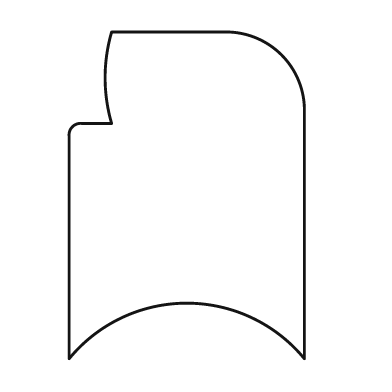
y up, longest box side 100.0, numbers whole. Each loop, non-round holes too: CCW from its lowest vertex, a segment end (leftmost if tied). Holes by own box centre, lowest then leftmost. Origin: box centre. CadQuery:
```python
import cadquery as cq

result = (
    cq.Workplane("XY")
    .moveTo(-36.0, -50.0)
    .threePointArc((0.0, -33.0), (36.0, -50.0))
    .lineTo(36.0, 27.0)
    .threePointArc((29.0, 43.0), (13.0, 50.0))
    .lineTo(-23.0, 50.0)
    .threePointArc((-25.0, 36.0), (-23.0, 22.0))
    .lineTo(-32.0, 22.0)
    .threePointArc((-35.0, 21.0), (-36.0, 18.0))
    .close()
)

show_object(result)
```